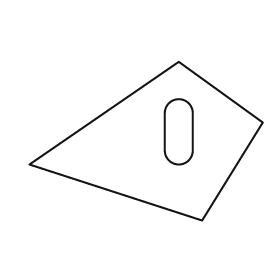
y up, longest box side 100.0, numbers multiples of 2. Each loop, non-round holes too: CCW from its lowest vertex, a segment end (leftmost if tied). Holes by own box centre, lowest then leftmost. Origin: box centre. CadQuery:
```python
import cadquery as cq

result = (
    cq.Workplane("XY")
    .moveTo(24.0, -34.0)
    .lineTo(50.0, 8.0)
    .lineTo(14.0, 34.0)
    .lineTo(-50.0, -10.0)
    .close()
    .moveTo(8.0, -4.0)
    .threePointArc((14.0, -10.0), (20.0, -4.0))
    .lineTo(20.0, 12.0)
    .threePointArc((14.0, 18.0), (8.0, 12.0))
    .close()
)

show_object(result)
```